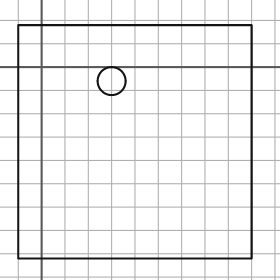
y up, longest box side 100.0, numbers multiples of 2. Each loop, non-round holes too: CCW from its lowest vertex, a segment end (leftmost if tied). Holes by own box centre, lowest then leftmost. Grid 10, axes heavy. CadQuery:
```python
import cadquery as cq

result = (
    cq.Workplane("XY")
    .moveTo(-10.0, -82.0)
    .lineTo(90.0, -82.0)
    .lineTo(90.0, 18.0)
    .lineTo(-10.0, 18.0)
    .close()
    .moveTo(30.0, -6.0)
    .circle(6.0)
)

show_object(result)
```